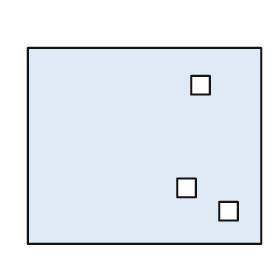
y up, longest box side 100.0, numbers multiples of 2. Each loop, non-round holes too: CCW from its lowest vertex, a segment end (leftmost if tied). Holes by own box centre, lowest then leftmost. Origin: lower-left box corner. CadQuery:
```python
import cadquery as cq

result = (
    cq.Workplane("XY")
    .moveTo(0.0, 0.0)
    .lineTo(100.0, 0.0)
    .lineTo(100.0, 84.0)
    .lineTo(0.0, 84.0)
    .close()
    .moveTo(82.0, 10.0)
    .lineTo(90.0, 10.0)
    .lineTo(90.0, 18.0)
    .lineTo(82.0, 18.0)
    .close()
    .moveTo(64.0, 20.0)
    .lineTo(72.0, 20.0)
    .lineTo(72.0, 28.0)
    .lineTo(64.0, 28.0)
    .close()
    .moveTo(70.0, 64.0)
    .lineTo(78.0, 64.0)
    .lineTo(78.0, 72.0)
    .lineTo(70.0, 72.0)
    .close()
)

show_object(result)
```